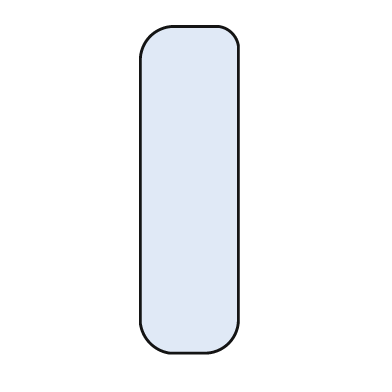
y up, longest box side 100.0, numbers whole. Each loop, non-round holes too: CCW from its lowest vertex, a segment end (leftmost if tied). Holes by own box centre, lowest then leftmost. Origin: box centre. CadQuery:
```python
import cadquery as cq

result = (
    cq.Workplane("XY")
    .moveTo(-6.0, -50.0)
    .lineTo(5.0, -50.0)
    .threePointArc((12.0, -47.0), (15.0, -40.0))
    .lineTo(15.0, 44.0)
    .threePointArc((13.0, 48.0), (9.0, 50.0))
    .lineTo(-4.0, 50.0)
    .threePointArc((-12.0, 47.0), (-15.0, 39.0))
    .lineTo(-15.0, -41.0)
    .threePointArc((-12.0, -47.0), (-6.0, -50.0))
    .close()
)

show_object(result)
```